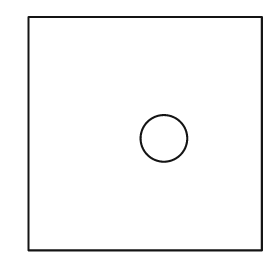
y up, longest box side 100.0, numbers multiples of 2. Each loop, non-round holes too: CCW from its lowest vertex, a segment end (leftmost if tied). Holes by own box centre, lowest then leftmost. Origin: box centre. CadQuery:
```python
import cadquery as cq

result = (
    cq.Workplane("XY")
    .moveTo(-50.0, -50.0)
    .lineTo(50.0, -50.0)
    .lineTo(50.0, 50.0)
    .lineTo(-50.0, 50.0)
    .close()
    .moveTo(8.0, -2.0)
    .circle(10.0)
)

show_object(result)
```